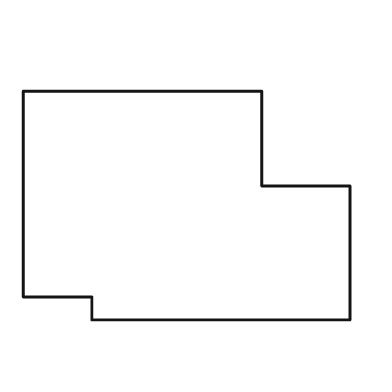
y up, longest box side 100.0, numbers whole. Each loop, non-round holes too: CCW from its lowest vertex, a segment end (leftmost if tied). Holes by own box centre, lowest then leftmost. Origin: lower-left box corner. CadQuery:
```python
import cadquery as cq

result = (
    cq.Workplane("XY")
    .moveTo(21.0, 0.0)
    .lineTo(100.0, 0.0)
    .lineTo(100.0, 41.0)
    .lineTo(73.0, 41.0)
    .lineTo(73.0, 70.0)
    .lineTo(0.0, 70.0)
    .lineTo(0.0, 7.0)
    .lineTo(21.0, 7.0)
    .close()
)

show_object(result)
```